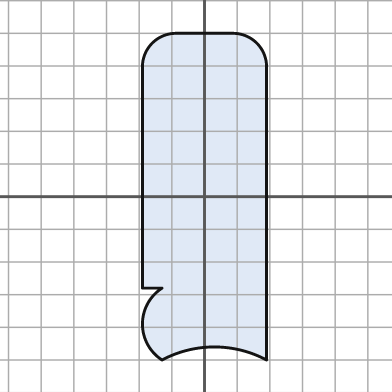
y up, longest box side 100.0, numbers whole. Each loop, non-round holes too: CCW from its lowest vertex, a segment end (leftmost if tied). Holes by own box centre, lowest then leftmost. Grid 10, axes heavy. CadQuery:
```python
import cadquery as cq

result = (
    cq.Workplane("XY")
    .moveTo(-13.0, -50.0)
    .threePointArc((3.0, -46.0), (19.0, -50.0))
    .lineTo(19.0, 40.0)
    .threePointArc((16.0, 47.0), (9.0, 50.0))
    .lineTo(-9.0, 50.0)
    .threePointArc((-16.0, 47.0), (-19.0, 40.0))
    .lineTo(-19.0, -28.0)
    .lineTo(-13.0, -28.0)
    .threePointArc((-19.0, -39.0), (-13.0, -50.0))
    .close()
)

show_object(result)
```